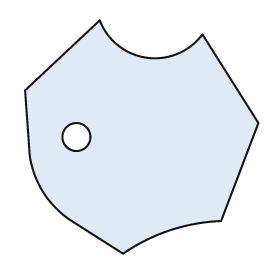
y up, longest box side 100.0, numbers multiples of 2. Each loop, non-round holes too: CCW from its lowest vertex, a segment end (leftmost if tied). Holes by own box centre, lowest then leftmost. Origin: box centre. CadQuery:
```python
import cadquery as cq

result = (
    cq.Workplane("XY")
    .moveTo(-8.0, -50.0)
    .threePointArc((12.0, -40.0), (34.0, -36.0))
    .lineTo(50.0, 6.0)
    .lineTo(26.0, 44.0)
    .threePointArc((2.0, 34.0), (-18.0, 50.0))
    .lineTo(-50.0, 20.0)
    .lineTo(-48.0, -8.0)
    .threePointArc((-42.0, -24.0), (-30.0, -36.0))
    .close()
    .moveTo(-28.0, 0.0)
    .circle(6.0)
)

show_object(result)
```